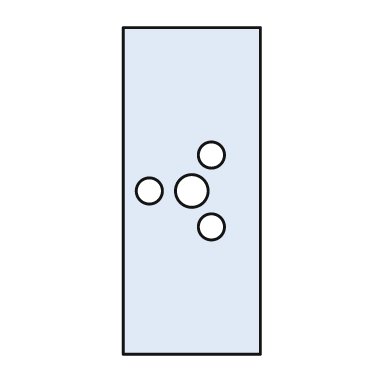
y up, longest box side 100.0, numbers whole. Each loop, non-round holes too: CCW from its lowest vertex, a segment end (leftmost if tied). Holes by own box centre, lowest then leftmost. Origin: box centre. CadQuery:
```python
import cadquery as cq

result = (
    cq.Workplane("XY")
    .moveTo(-21.0, -50.0)
    .lineTo(21.0, -50.0)
    .lineTo(21.0, 50.0)
    .lineTo(-21.0, 50.0)
    .close()
    .moveTo(6.0, -11.0)
    .circle(4.0)
    .moveTo(-13.0, 0.0)
    .circle(4.0)
    .moveTo(0.0, 0.0)
    .circle(5.0)
    .moveTo(6.0, 11.0)
    .circle(4.0)
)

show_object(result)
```